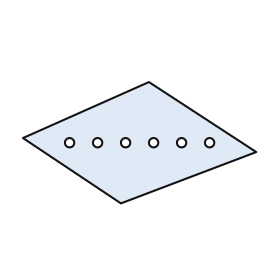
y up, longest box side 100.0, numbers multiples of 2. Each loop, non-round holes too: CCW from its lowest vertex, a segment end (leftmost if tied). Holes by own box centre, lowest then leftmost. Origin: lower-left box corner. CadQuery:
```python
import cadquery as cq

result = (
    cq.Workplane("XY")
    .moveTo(42.0, 0.0)
    .lineTo(100.0, 22.0)
    .lineTo(54.0, 52.0)
    .lineTo(0.0, 28.0)
    .close()
    .moveTo(20.0, 26.0)
    .circle(2.0)
    .moveTo(32.0, 26.0)
    .circle(2.0)
    .moveTo(44.0, 26.0)
    .circle(2.0)
    .moveTo(56.0, 26.0)
    .circle(2.0)
    .moveTo(68.0, 26.0)
    .circle(2.0)
    .moveTo(80.0, 26.0)
    .circle(2.0)
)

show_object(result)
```